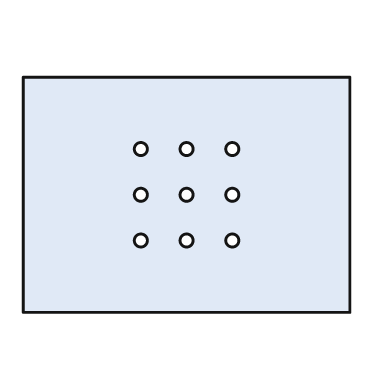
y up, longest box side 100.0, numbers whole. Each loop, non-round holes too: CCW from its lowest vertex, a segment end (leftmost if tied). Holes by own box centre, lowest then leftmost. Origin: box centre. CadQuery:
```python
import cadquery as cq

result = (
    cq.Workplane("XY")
    .moveTo(-50.0, -36.0)
    .lineTo(50.0, -36.0)
    .lineTo(50.0, 36.0)
    .lineTo(-50.0, 36.0)
    .close()
    .moveTo(-14.0, -14.0)
    .circle(2.0)
    .moveTo(0.0, -14.0)
    .circle(2.0)
    .moveTo(14.0, -14.0)
    .circle(2.0)
    .moveTo(-14.0, 0.0)
    .circle(2.0)
    .moveTo(0.0, 0.0)
    .circle(2.0)
    .moveTo(14.0, 0.0)
    .circle(2.0)
    .moveTo(-14.0, 14.0)
    .circle(2.0)
    .moveTo(0.0, 14.0)
    .circle(2.0)
    .moveTo(14.0, 14.0)
    .circle(2.0)
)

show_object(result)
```